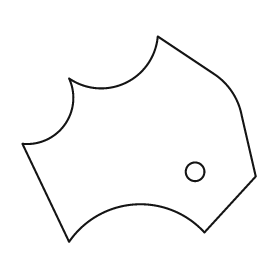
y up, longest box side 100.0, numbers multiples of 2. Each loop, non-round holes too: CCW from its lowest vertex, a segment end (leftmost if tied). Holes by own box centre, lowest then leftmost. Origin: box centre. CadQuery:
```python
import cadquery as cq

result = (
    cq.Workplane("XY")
    .moveTo(-30.0, -44.0)
    .threePointArc((-2.0, -28.0), (28.0, -40.0))
    .lineTo(50.0, -16.0)
    .lineTo(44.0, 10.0)
    .threePointArc((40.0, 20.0), (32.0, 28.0))
    .lineTo(8.0, 44.0)
    .threePointArc((-6.0, 24.0), (-30.0, 26.0))
    .threePointArc((-32.0, 6.0), (-50.0, -2.0))
    .close()
    .moveTo(24.0, -14.0)
    .circle(4.0)
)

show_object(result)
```